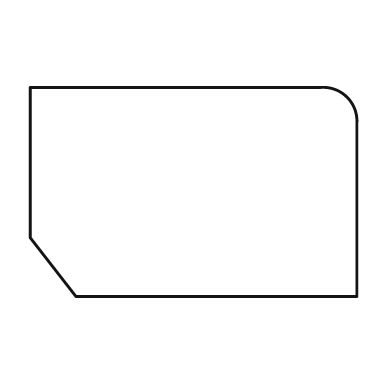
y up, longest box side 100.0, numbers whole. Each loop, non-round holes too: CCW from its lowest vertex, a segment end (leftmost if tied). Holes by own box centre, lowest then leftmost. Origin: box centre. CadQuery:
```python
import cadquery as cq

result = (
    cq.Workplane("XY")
    .moveTo(-36.0, -32.0)
    .lineTo(50.0, -32.0)
    .lineTo(50.0, 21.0)
    .threePointArc((47.0, 29.0), (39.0, 32.0))
    .lineTo(-50.0, 32.0)
    .lineTo(-50.0, -14.0)
    .close()
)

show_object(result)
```